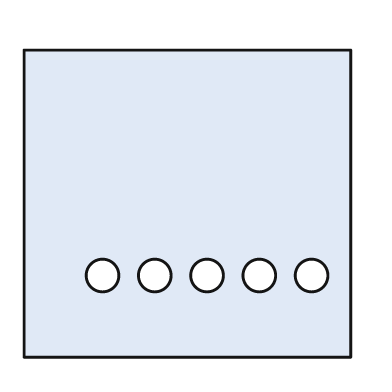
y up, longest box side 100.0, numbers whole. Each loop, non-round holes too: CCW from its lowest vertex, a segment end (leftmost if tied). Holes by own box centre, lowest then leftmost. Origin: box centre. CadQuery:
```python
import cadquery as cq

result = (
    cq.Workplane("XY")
    .moveTo(-50.0, -47.0)
    .lineTo(50.0, -47.0)
    .lineTo(50.0, 47.0)
    .lineTo(-50.0, 47.0)
    .close()
    .moveTo(-26.0, -22.0)
    .circle(5.0)
    .moveTo(-10.0, -22.0)
    .circle(5.0)
    .moveTo(6.0, -22.0)
    .circle(5.0)
    .moveTo(22.0, -22.0)
    .circle(5.0)
    .moveTo(38.0, -22.0)
    .circle(5.0)
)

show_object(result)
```